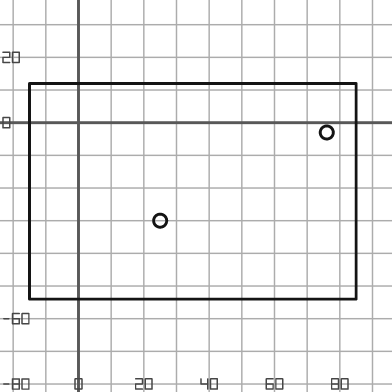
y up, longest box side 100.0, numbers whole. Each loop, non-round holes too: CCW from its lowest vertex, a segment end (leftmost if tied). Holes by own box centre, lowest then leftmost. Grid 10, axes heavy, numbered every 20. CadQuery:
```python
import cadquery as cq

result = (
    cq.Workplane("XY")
    .moveTo(-15.0, -54.0)
    .lineTo(85.0, -54.0)
    .lineTo(85.0, 12.0)
    .lineTo(-15.0, 12.0)
    .close()
    .moveTo(25.0, -30.0)
    .circle(2.0)
    .moveTo(76.0, -3.0)
    .circle(2.0)
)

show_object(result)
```